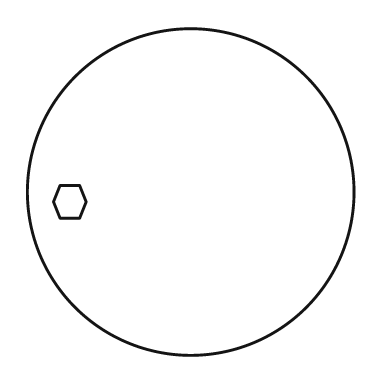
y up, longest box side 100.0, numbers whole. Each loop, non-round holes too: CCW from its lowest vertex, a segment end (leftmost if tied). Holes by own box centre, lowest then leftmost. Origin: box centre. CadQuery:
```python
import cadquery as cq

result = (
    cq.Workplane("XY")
    .moveTo(0.0, 0.0)
    .circle(50.0)
    .moveTo(-40.0, -8.0)
    .lineTo(-34.0, -8.0)
    .lineTo(-32.0, -3.0)
    .lineTo(-34.0, 2.0)
    .lineTo(-40.0, 2.0)
    .lineTo(-42.0, -3.0)
    .close()
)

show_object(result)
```